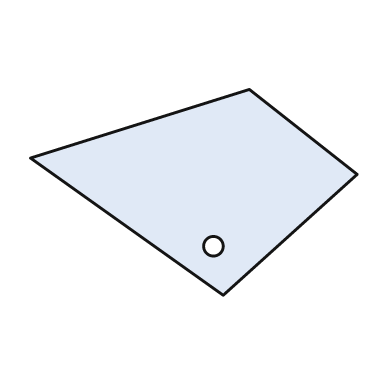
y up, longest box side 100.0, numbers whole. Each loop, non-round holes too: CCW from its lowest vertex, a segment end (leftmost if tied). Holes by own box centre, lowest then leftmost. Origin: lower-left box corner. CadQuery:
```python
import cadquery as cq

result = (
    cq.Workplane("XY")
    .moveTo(59.0, 0.0)
    .lineTo(100.0, 37.0)
    .lineTo(67.0, 63.0)
    .lineTo(0.0, 42.0)
    .close()
    .moveTo(56.0, 15.0)
    .circle(3.0)
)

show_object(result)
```